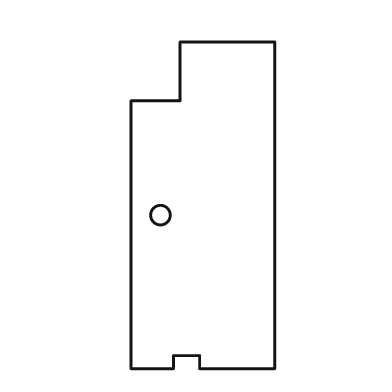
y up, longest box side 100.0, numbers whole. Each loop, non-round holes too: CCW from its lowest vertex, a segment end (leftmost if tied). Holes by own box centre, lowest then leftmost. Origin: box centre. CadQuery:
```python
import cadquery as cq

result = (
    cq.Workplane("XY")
    .moveTo(-22.0, -50.0)
    .lineTo(-9.0, -50.0)
    .lineTo(-9.0, -46.0)
    .lineTo(-1.0, -46.0)
    .lineTo(-1.0, -50.0)
    .lineTo(22.0, -50.0)
    .lineTo(22.0, 50.0)
    .lineTo(-7.0, 50.0)
    .lineTo(-7.0, 32.0)
    .lineTo(-22.0, 32.0)
    .close()
    .moveTo(-13.0, -3.0)
    .circle(3.0)
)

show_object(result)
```